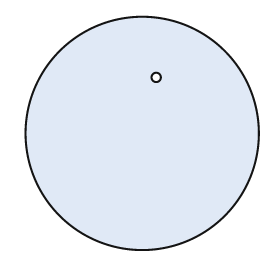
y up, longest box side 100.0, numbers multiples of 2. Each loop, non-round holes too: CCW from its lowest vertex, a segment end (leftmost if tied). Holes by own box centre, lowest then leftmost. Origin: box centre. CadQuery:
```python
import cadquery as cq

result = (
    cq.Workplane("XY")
    .moveTo(0.0, 0.0)
    .circle(50.0)
    .moveTo(6.0, 24.0)
    .circle(2.0)
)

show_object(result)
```